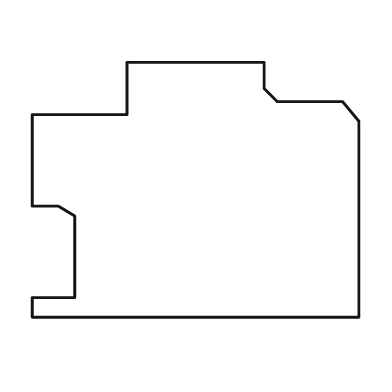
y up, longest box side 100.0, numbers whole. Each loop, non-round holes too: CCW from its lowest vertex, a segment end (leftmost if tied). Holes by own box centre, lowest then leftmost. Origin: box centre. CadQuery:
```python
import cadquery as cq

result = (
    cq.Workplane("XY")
    .moveTo(-50.0, -39.0)
    .lineTo(50.0, -39.0)
    .lineTo(50.0, 21.0)
    .lineTo(45.0, 27.0)
    .lineTo(25.0, 27.0)
    .lineTo(21.0, 31.0)
    .lineTo(21.0, 39.0)
    .lineTo(-21.0, 39.0)
    .lineTo(-21.0, 23.0)
    .lineTo(-50.0, 23.0)
    .lineTo(-50.0, -5.0)
    .lineTo(-42.0, -5.0)
    .lineTo(-37.0, -8.0)
    .lineTo(-37.0, -33.0)
    .lineTo(-50.0, -33.0)
    .close()
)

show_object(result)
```